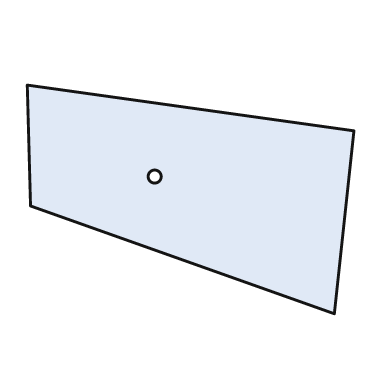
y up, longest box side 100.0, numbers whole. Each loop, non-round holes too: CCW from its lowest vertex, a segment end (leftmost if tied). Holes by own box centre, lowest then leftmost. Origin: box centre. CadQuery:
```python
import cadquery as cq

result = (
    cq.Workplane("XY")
    .moveTo(44.0, -35.0)
    .lineTo(50.0, 21.0)
    .lineTo(-50.0, 35.0)
    .lineTo(-49.0, -2.0)
    .close()
    .moveTo(-11.0, 7.0)
    .circle(2.0)
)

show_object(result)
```